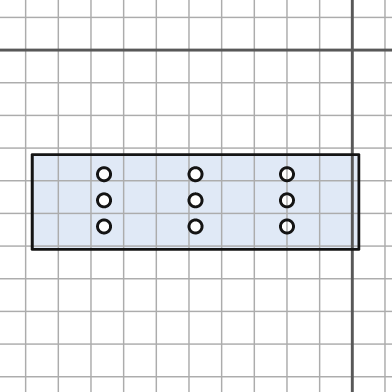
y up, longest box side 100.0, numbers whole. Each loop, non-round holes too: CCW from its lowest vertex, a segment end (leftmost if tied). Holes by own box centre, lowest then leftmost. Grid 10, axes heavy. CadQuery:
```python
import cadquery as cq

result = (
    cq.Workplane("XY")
    .moveTo(-98.0, -61.0)
    .lineTo(2.0, -61.0)
    .lineTo(2.0, -32.0)
    .lineTo(-98.0, -32.0)
    .close()
    .moveTo(-76.0, -54.0)
    .circle(2.0)
    .moveTo(-48.0, -54.0)
    .circle(2.0)
    .moveTo(-20.0, -54.0)
    .circle(2.0)
    .moveTo(-76.0, -46.0)
    .circle(2.0)
    .moveTo(-48.0, -46.0)
    .circle(2.0)
    .moveTo(-20.0, -46.0)
    .circle(2.0)
    .moveTo(-76.0, -38.0)
    .circle(2.0)
    .moveTo(-48.0, -38.0)
    .circle(2.0)
    .moveTo(-20.0, -38.0)
    .circle(2.0)
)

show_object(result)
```